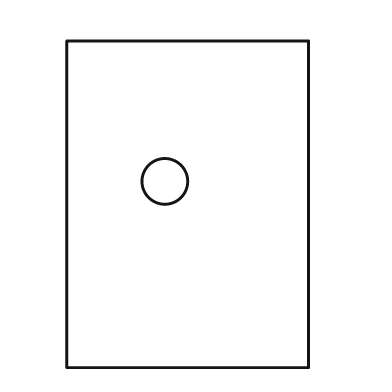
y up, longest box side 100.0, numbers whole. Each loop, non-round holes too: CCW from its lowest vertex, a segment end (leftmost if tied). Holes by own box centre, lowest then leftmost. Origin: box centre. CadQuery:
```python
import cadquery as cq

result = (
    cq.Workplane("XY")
    .moveTo(-37.0, -50.0)
    .lineTo(37.0, -50.0)
    .lineTo(37.0, 50.0)
    .lineTo(-37.0, 50.0)
    .close()
    .moveTo(-7.0, 7.0)
    .circle(7.0)
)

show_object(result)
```